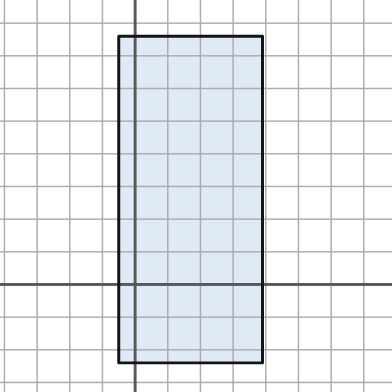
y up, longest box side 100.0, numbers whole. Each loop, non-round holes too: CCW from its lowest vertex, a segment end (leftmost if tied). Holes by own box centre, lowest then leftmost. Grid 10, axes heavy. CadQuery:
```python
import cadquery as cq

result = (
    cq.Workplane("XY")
    .moveTo(-5.0, -24.0)
    .lineTo(39.0, -24.0)
    .lineTo(39.0, 76.0)
    .lineTo(-5.0, 76.0)
    .close()
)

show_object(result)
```